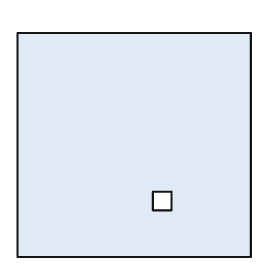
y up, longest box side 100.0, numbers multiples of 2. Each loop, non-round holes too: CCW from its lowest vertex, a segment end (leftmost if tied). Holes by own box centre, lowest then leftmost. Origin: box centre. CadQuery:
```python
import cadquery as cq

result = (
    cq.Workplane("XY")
    .moveTo(-50.0, -48.0)
    .lineTo(50.0, -48.0)
    .lineTo(50.0, 48.0)
    .lineTo(-50.0, 48.0)
    .close()
    .moveTo(8.0, -28.0)
    .lineTo(16.0, -28.0)
    .lineTo(16.0, -20.0)
    .lineTo(8.0, -20.0)
    .close()
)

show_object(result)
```